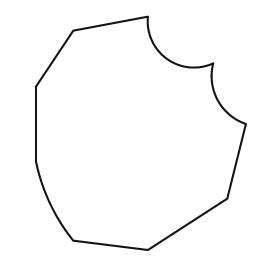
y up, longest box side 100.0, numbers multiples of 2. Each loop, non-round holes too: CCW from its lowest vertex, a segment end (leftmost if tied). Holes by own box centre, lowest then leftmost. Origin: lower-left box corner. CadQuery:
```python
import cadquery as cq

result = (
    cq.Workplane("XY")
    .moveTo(48.0, 0.0)
    .lineTo(82.0, 22.0)
    .lineTo(90.0, 54.0)
    .threePointArc((78.0, 64.0), (76.0, 80.0))
    .threePointArc((56.0, 82.0), (48.0, 100.0))
    .lineTo(16.0, 94.0)
    .lineTo(0.0, 70.0)
    .lineTo(0.0, 38.0)
    .threePointArc((6.0, 20.0), (16.0, 4.0))
    .close()
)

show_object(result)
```